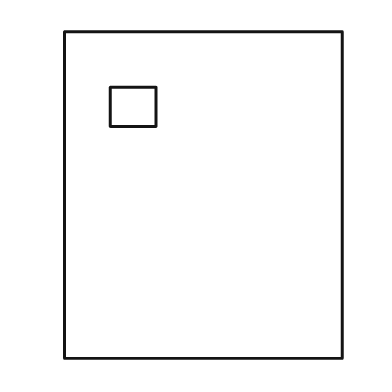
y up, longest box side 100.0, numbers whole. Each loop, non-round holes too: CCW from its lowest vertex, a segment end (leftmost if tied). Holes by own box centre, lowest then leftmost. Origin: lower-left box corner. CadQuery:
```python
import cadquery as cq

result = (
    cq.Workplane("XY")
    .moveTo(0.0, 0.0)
    .lineTo(85.0, 0.0)
    .lineTo(85.0, 100.0)
    .lineTo(0.0, 100.0)
    .close()
    .moveTo(14.0, 71.0)
    .lineTo(28.0, 71.0)
    .lineTo(28.0, 83.0)
    .lineTo(14.0, 83.0)
    .close()
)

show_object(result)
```